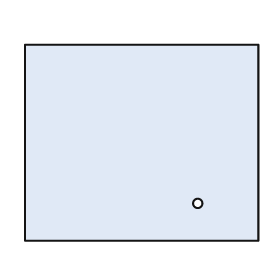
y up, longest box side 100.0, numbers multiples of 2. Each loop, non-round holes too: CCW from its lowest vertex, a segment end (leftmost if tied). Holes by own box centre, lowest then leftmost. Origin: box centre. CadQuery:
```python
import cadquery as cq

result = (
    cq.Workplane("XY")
    .moveTo(-50.0, -42.0)
    .lineTo(50.0, -42.0)
    .lineTo(50.0, 42.0)
    .lineTo(-50.0, 42.0)
    .close()
    .moveTo(24.0, -26.0)
    .circle(2.0)
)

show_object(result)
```